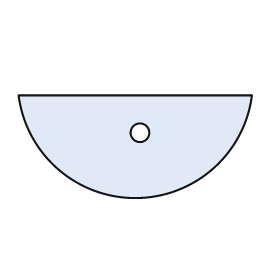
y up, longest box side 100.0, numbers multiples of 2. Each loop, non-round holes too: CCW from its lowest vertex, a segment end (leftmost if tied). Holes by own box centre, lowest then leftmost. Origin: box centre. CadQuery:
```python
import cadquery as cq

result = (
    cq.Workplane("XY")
    .moveTo(-50.0, 22.0)
    .threePointArc((0.0, -22.0), (50.0, 22.0))
    .close()
    .moveTo(2.0, 6.0)
    .circle(4.0)
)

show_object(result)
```